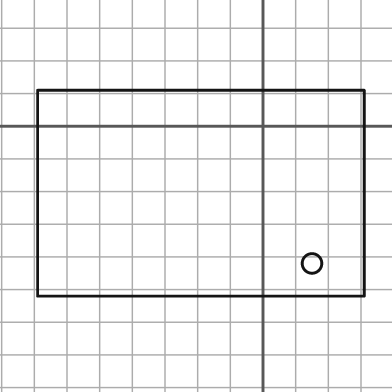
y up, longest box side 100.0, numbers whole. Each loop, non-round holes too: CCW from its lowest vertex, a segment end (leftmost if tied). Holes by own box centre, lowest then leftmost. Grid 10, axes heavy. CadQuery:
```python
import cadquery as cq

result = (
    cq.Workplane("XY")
    .moveTo(-69.0, -52.0)
    .lineTo(31.0, -52.0)
    .lineTo(31.0, 11.0)
    .lineTo(-69.0, 11.0)
    .close()
    .moveTo(15.0, -42.0)
    .circle(3.0)
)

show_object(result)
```